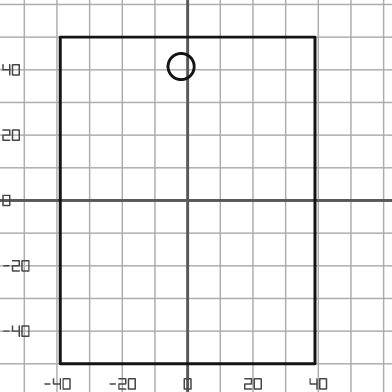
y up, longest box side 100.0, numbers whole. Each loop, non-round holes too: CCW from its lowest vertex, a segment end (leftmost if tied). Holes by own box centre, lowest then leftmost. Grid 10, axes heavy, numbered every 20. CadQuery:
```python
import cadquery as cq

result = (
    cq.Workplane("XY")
    .moveTo(-39.0, -50.0)
    .lineTo(39.0, -50.0)
    .lineTo(39.0, 50.0)
    .lineTo(-39.0, 50.0)
    .close()
    .moveTo(-2.0, 41.0)
    .circle(4.0)
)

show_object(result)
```